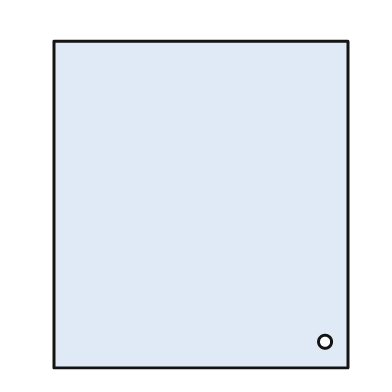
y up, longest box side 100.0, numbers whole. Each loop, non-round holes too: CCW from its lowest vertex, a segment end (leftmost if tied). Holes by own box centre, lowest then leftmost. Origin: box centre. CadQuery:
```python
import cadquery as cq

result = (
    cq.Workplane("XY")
    .moveTo(-45.0, -50.0)
    .lineTo(45.0, -50.0)
    .lineTo(45.0, 50.0)
    .lineTo(-45.0, 50.0)
    .close()
    .moveTo(38.0, -42.0)
    .circle(2.0)
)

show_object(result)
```